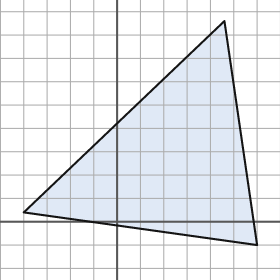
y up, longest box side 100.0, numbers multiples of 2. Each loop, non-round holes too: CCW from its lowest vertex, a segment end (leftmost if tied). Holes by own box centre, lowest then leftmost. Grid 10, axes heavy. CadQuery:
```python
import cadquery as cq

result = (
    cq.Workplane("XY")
    .moveTo(60.0, -10.0)
    .lineTo(46.0, 86.0)
    .lineTo(-40.0, 4.0)
    .close()
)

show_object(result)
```